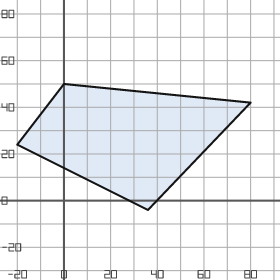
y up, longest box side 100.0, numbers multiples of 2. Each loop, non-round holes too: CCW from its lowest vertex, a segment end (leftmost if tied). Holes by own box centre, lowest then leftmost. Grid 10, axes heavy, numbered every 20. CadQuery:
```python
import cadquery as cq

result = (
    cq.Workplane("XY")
    .moveTo(36.0, -4.0)
    .lineTo(80.0, 42.0)
    .lineTo(0.0, 50.0)
    .lineTo(-20.0, 24.0)
    .close()
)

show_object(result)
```